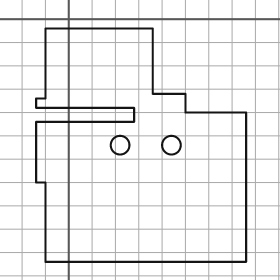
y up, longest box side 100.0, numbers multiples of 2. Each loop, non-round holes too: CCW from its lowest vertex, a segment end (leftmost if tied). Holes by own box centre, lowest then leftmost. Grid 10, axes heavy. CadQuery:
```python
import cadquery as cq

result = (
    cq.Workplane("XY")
    .moveTo(-10.0, -104.0)
    .lineTo(76.0, -104.0)
    .lineTo(76.0, -40.0)
    .lineTo(50.0, -40.0)
    .lineTo(50.0, -32.0)
    .lineTo(36.0, -32.0)
    .lineTo(36.0, -4.0)
    .lineTo(-10.0, -4.0)
    .lineTo(-10.0, -34.0)
    .lineTo(-14.0, -34.0)
    .lineTo(-14.0, -38.0)
    .lineTo(28.0, -38.0)
    .lineTo(28.0, -44.0)
    .lineTo(-14.0, -44.0)
    .lineTo(-14.0, -70.0)
    .lineTo(-10.0, -70.0)
    .close()
    .moveTo(22.0, -54.0)
    .circle(4.0)
    .moveTo(44.0, -54.0)
    .circle(4.0)
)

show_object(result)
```